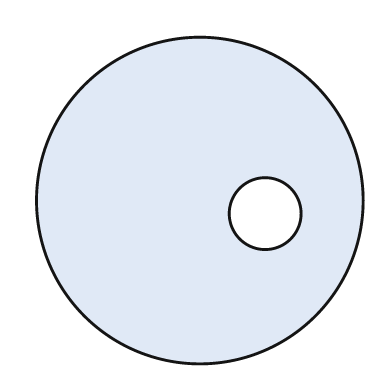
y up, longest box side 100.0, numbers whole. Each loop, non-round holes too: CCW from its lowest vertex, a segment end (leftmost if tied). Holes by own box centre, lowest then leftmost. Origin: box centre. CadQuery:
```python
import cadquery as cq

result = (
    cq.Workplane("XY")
    .moveTo(0.0, 0.0)
    .circle(50.0)
    .moveTo(20.0, -4.0)
    .circle(11.0)
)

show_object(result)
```